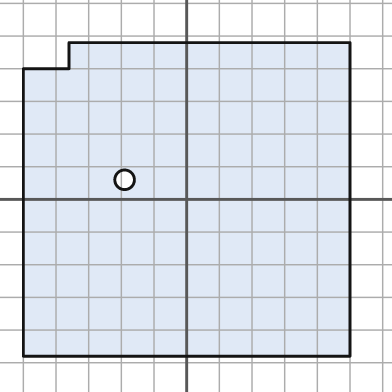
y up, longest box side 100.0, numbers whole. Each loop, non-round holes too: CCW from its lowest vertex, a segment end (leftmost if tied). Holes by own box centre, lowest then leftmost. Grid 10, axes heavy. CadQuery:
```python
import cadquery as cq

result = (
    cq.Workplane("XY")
    .moveTo(-50.0, -48.0)
    .lineTo(50.0, -48.0)
    .lineTo(50.0, 48.0)
    .lineTo(-36.0, 48.0)
    .lineTo(-36.0, 40.0)
    .lineTo(-50.0, 40.0)
    .close()
    .moveTo(-19.0, 6.0)
    .circle(3.0)
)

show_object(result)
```